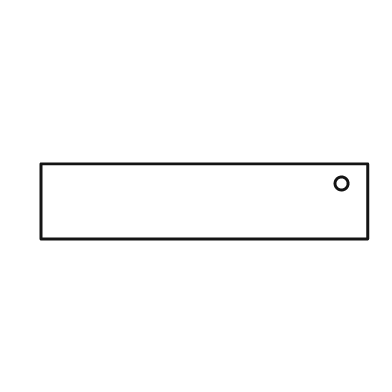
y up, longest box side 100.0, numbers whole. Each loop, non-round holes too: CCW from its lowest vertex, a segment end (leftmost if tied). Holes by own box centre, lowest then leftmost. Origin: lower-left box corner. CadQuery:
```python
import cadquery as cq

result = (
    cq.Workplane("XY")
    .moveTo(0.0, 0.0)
    .lineTo(100.0, 0.0)
    .lineTo(100.0, 23.0)
    .lineTo(0.0, 23.0)
    .close()
    .moveTo(92.0, 17.0)
    .circle(2.0)
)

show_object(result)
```